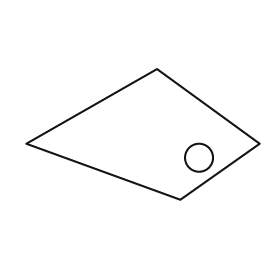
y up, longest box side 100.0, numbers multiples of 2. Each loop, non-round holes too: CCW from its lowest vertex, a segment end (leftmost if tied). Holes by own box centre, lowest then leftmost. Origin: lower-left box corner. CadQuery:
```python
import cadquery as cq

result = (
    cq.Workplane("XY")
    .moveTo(66.0, 0.0)
    .lineTo(100.0, 24.0)
    .lineTo(56.0, 56.0)
    .lineTo(0.0, 24.0)
    .close()
    .moveTo(74.0, 18.0)
    .circle(6.0)
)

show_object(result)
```